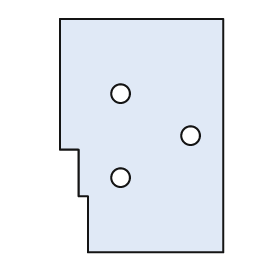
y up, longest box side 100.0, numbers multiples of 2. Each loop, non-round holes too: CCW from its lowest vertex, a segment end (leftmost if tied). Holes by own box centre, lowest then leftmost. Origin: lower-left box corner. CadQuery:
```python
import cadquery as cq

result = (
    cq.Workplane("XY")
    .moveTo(12.0, 0.0)
    .lineTo(70.0, 0.0)
    .lineTo(70.0, 100.0)
    .lineTo(0.0, 100.0)
    .lineTo(0.0, 44.0)
    .lineTo(8.0, 44.0)
    .lineTo(8.0, 24.0)
    .lineTo(12.0, 24.0)
    .close()
    .moveTo(26.0, 32.0)
    .circle(4.0)
    .moveTo(56.0, 50.0)
    .circle(4.0)
    .moveTo(26.0, 68.0)
    .circle(4.0)
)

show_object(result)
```